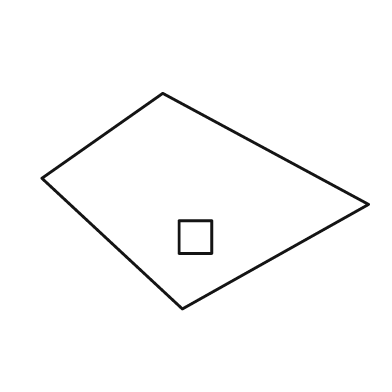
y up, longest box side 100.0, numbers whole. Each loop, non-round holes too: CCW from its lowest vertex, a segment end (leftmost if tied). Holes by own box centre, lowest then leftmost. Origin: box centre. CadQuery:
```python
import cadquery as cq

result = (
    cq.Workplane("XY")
    .moveTo(-7.0, -33.0)
    .lineTo(50.0, -1.0)
    .lineTo(-13.0, 33.0)
    .lineTo(-50.0, 7.0)
    .close()
    .moveTo(-8.0, -16.0)
    .lineTo(2.0, -16.0)
    .lineTo(2.0, -6.0)
    .lineTo(-8.0, -6.0)
    .close()
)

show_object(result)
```